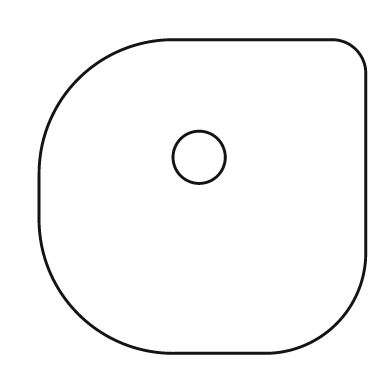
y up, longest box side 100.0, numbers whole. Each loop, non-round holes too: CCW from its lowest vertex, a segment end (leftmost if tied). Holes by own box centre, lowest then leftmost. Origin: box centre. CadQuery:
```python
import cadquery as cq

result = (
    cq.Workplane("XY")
    .moveTo(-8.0, -48.0)
    .lineTo(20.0, -48.0)
    .threePointArc((41.0, -39.0), (50.0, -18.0))
    .lineTo(50.0, 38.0)
    .threePointArc((47.0, 45.0), (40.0, 48.0))
    .lineTo(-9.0, 48.0)
    .threePointArc((-38.0, 36.0), (-50.0, 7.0))
    .lineTo(-50.0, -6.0)
    .threePointArc((-38.0, -36.0), (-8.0, -48.0))
    .close()
    .moveTo(-1.0, 12.0)
    .circle(8.0)
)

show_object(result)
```